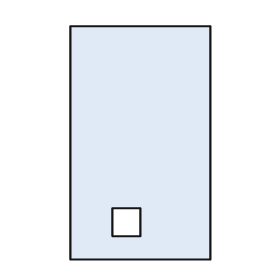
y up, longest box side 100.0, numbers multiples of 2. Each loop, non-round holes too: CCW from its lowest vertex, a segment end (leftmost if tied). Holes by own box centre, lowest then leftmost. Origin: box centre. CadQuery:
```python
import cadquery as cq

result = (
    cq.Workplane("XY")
    .moveTo(-30.0, -50.0)
    .lineTo(30.0, -50.0)
    .lineTo(30.0, 50.0)
    .lineTo(-30.0, 50.0)
    .close()
    .moveTo(-12.0, -40.0)
    .lineTo(0.0, -40.0)
    .lineTo(0.0, -28.0)
    .lineTo(-12.0, -28.0)
    .close()
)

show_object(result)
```